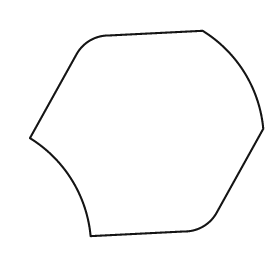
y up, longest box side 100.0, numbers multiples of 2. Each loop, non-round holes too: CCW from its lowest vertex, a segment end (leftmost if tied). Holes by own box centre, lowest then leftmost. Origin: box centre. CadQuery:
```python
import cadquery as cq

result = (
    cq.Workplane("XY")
    .moveTo(-24.0, -44.0)
    .lineTo(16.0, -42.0)
    .threePointArc((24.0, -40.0), (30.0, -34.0))
    .lineTo(50.0, 2.0)
    .threePointArc((42.0, 26.0), (24.0, 44.0))
    .lineTo(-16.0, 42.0)
    .threePointArc((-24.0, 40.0), (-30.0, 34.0))
    .lineTo(-50.0, -2.0)
    .threePointArc((-32.0, -20.0), (-24.0, -44.0))
    .close()
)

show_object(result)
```